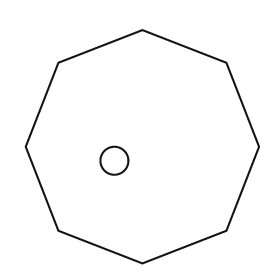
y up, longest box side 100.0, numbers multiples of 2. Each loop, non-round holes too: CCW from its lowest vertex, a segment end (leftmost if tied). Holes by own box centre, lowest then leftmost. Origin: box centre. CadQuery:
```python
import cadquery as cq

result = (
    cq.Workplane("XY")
    .moveTo(0.0, -50.0)
    .lineTo(36.0, -36.0)
    .lineTo(50.0, 0.0)
    .lineTo(36.0, 36.0)
    .lineTo(0.0, 50.0)
    .lineTo(-36.0, 36.0)
    .lineTo(-50.0, 0.0)
    .lineTo(-36.0, -36.0)
    .close()
    .moveTo(-12.0, -6.0)
    .circle(6.0)
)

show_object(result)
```